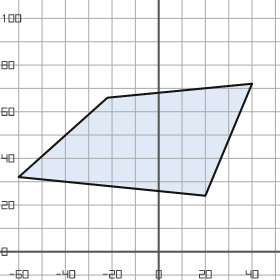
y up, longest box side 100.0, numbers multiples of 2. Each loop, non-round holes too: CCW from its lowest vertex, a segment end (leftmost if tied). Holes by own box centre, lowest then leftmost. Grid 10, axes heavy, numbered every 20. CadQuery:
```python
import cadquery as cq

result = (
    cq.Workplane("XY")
    .moveTo(20.0, 24.0)
    .lineTo(40.0, 72.0)
    .lineTo(-22.0, 66.0)
    .lineTo(-60.0, 32.0)
    .close()
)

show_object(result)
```